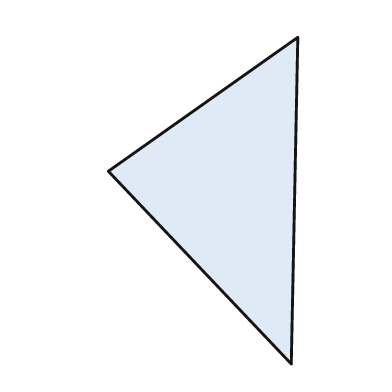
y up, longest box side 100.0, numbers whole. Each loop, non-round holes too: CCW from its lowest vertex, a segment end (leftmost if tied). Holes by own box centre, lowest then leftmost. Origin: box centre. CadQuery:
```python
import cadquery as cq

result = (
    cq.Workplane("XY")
    .moveTo(27.0, -50.0)
    .lineTo(29.0, 50.0)
    .lineTo(-29.0, 9.0)
    .close()
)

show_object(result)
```